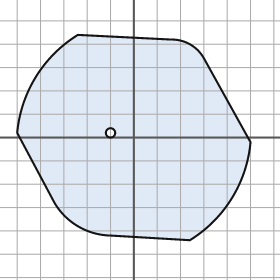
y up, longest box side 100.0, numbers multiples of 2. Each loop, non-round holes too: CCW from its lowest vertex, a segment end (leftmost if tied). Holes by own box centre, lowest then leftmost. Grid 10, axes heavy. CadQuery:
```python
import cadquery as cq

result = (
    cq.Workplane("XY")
    .moveTo(24.0, -44.0)
    .threePointArc((42.0, -26.0), (50.0, -2.0))
    .lineTo(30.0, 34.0)
    .threePointArc((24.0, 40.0), (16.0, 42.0))
    .lineTo(-24.0, 44.0)
    .threePointArc((-42.0, 26.0), (-50.0, 2.0))
    .lineTo(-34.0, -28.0)
    .threePointArc((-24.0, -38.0), (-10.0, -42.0))
    .close()
    .moveTo(-10.0, 2.0)
    .circle(2.0)
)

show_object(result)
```